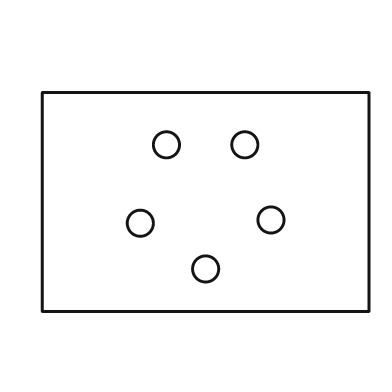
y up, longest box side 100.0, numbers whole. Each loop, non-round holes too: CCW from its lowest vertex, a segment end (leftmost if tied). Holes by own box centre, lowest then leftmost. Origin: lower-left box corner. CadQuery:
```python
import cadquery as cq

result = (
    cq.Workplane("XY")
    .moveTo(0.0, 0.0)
    .lineTo(100.0, 0.0)
    .lineTo(100.0, 67.0)
    .lineTo(0.0, 67.0)
    .close()
    .moveTo(50.0, 13.0)
    .circle(4.0)
    .moveTo(30.0, 27.0)
    .circle(4.0)
    .moveTo(70.0, 28.0)
    .circle(4.0)
    .moveTo(38.0, 51.0)
    .circle(4.0)
    .moveTo(62.0, 51.0)
    .circle(4.0)
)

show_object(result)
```